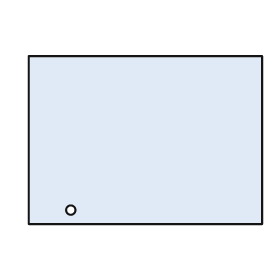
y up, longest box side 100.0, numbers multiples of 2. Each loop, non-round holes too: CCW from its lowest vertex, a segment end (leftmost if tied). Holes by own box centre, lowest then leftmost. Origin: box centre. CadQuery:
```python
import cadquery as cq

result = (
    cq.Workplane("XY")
    .moveTo(-50.0, -36.0)
    .lineTo(50.0, -36.0)
    .lineTo(50.0, 36.0)
    .lineTo(-50.0, 36.0)
    .close()
    .moveTo(-32.0, -30.0)
    .circle(2.0)
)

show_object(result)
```